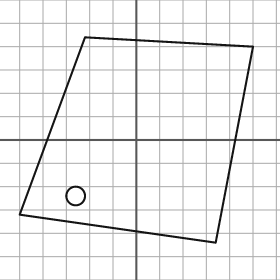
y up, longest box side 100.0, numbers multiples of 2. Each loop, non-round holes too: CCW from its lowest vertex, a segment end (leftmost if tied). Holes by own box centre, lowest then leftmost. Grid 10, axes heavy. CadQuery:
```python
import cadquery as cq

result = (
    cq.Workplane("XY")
    .moveTo(34.0, -44.0)
    .lineTo(50.0, 40.0)
    .lineTo(-22.0, 44.0)
    .lineTo(-50.0, -32.0)
    .close()
    .moveTo(-26.0, -24.0)
    .circle(4.0)
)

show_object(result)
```